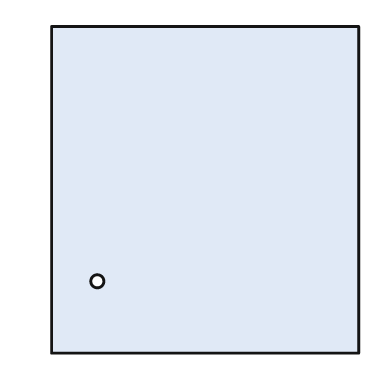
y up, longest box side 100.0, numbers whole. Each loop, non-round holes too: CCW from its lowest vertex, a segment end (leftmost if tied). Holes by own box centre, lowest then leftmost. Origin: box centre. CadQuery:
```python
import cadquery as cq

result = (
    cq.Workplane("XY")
    .moveTo(-47.0, -50.0)
    .lineTo(47.0, -50.0)
    .lineTo(47.0, 50.0)
    .lineTo(-47.0, 50.0)
    .close()
    .moveTo(-33.0, -28.0)
    .circle(2.0)
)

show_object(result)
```